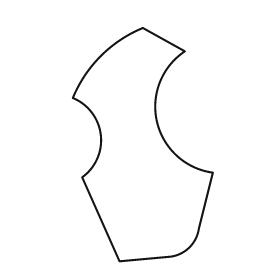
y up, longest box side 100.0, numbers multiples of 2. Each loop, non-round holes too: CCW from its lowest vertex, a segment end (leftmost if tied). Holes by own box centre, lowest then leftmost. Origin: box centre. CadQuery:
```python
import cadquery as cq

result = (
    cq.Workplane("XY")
    .moveTo(-10.0, -50.0)
    .lineTo(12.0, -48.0)
    .threePointArc((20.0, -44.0), (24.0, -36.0))
    .lineTo(30.0, -12.0)
    .threePointArc((6.0, 10.0), (18.0, 40.0))
    .lineTo(0.0, 50.0)
    .threePointArc((-18.0, 38.0), (-30.0, 20.0))
    .threePointArc((-18.0, 4.0), (-26.0, -14.0))
    .close()
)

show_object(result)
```